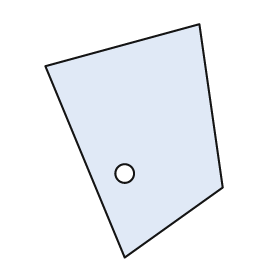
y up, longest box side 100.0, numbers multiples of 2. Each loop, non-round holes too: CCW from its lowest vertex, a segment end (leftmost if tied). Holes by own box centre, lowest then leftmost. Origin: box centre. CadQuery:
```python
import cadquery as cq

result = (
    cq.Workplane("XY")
    .moveTo(-4.0, -50.0)
    .lineTo(38.0, -20.0)
    .lineTo(28.0, 50.0)
    .lineTo(-38.0, 32.0)
    .close()
    .moveTo(-4.0, -14.0)
    .circle(4.0)
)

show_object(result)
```